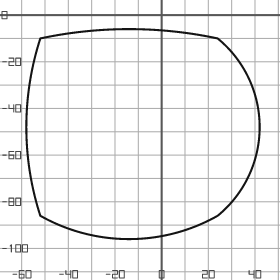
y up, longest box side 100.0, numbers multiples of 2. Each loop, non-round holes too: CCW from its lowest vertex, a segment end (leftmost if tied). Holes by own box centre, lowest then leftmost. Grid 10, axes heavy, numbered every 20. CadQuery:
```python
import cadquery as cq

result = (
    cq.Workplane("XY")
    .moveTo(-52.0, -86.0)
    .threePointArc((-14.0, -96.0), (24.0, -86.0))
    .threePointArc((42.0, -48.0), (24.0, -10.0))
    .threePointArc((-14.0, -6.0), (-52.0, -10.0))
    .threePointArc((-58.0, -48.0), (-52.0, -86.0))
    .close()
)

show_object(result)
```